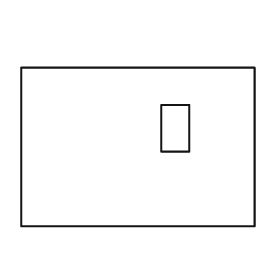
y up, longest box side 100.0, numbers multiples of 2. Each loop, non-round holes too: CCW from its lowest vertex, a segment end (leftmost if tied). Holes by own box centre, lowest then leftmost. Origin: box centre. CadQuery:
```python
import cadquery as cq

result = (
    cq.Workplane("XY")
    .moveTo(-50.0, -34.0)
    .lineTo(50.0, -34.0)
    .lineTo(50.0, 34.0)
    .lineTo(-50.0, 34.0)
    .close()
    .moveTo(10.0, -2.0)
    .lineTo(22.0, -2.0)
    .lineTo(22.0, 18.0)
    .lineTo(10.0, 18.0)
    .close()
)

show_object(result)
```